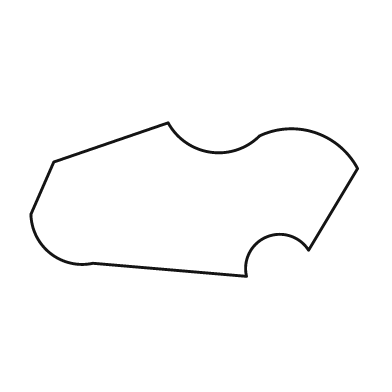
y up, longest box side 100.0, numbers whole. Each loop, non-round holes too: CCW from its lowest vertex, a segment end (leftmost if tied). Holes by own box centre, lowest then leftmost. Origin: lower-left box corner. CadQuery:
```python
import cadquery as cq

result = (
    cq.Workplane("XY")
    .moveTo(66.0, 0.0)
    .threePointArc((72.0, 12.0), (85.0, 8.0))
    .lineTo(100.0, 33.0)
    .threePointArc((87.0, 44.0), (70.0, 43.0))
    .threePointArc((55.0, 38.0), (42.0, 47.0))
    .lineTo(7.0, 35.0)
    .lineTo(0.0, 19.0)
    .threePointArc((6.0, 7.0), (19.0, 4.0))
    .close()
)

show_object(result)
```